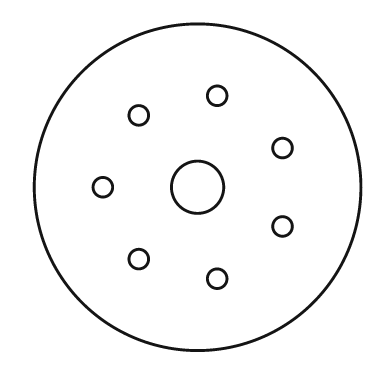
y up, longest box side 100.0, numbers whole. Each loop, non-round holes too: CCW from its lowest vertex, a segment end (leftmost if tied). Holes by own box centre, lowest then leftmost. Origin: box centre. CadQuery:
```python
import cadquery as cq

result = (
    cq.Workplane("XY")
    .moveTo(0.0, 0.0)
    .circle(50.0)
    .moveTo(6.0, -28.0)
    .circle(3.0)
    .moveTo(-18.0, -22.0)
    .circle(3.0)
    .moveTo(26.0, -12.0)
    .circle(3.0)
    .moveTo(-29.0, 0.0)
    .circle(3.0)
    .moveTo(0.0, 0.0)
    .circle(8.0)
    .moveTo(26.0, 12.0)
    .circle(3.0)
    .moveTo(-18.0, 22.0)
    .circle(3.0)
    .moveTo(6.0, 28.0)
    .circle(3.0)
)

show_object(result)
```